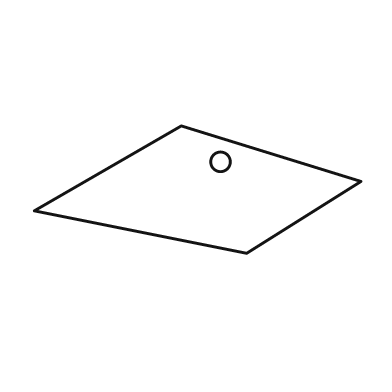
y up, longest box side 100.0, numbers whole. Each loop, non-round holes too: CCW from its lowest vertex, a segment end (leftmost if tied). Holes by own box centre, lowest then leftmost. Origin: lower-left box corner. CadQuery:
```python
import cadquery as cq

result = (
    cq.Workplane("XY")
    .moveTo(65.0, 0.0)
    .lineTo(100.0, 22.0)
    .lineTo(45.0, 39.0)
    .lineTo(0.0, 13.0)
    .close()
    .moveTo(57.0, 28.0)
    .circle(3.0)
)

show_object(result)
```